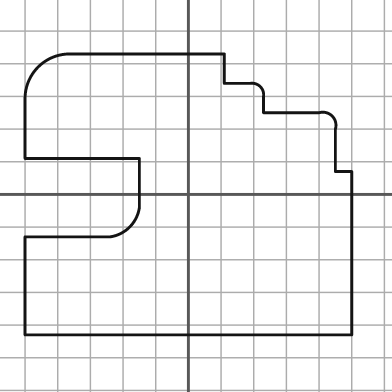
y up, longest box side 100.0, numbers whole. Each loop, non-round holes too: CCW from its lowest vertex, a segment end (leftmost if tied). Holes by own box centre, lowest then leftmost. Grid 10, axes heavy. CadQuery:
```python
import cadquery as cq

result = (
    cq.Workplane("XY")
    .moveTo(-50.0, -43.0)
    .lineTo(50.0, -43.0)
    .lineTo(50.0, 7.0)
    .lineTo(45.0, 7.0)
    .lineTo(45.0, 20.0)
    .threePointArc((44.0, 24.0), (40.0, 25.0))
    .lineTo(23.0, 25.0)
    .lineTo(23.0, 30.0)
    .threePointArc((22.0, 33.0), (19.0, 34.0))
    .lineTo(11.0, 34.0)
    .lineTo(11.0, 43.0)
    .lineTo(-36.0, 43.0)
    .threePointArc((-46.0, 39.0), (-50.0, 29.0))
    .lineTo(-50.0, 11.0)
    .lineTo(-15.0, 11.0)
    .lineTo(-15.0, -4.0)
    .threePointArc((-18.0, -10.0), (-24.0, -13.0))
    .lineTo(-50.0, -13.0)
    .close()
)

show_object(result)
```